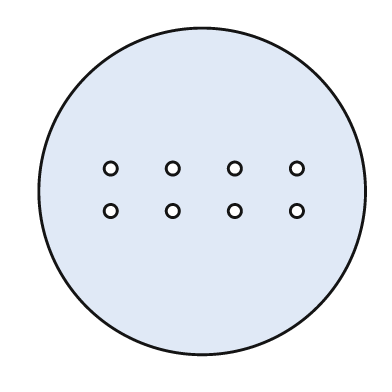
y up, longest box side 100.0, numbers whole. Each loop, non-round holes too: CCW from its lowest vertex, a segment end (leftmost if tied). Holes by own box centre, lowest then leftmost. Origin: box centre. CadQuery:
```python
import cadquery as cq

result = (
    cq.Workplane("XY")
    .moveTo(0.0, 0.0)
    .circle(50.0)
    .moveTo(-28.0, -6.0)
    .circle(2.0)
    .moveTo(-9.0, -6.0)
    .circle(2.0)
    .moveTo(10.0, -6.0)
    .circle(2.0)
    .moveTo(29.0, -6.0)
    .circle(2.0)
    .moveTo(-28.0, 7.0)
    .circle(2.0)
    .moveTo(-9.0, 7.0)
    .circle(2.0)
    .moveTo(10.0, 7.0)
    .circle(2.0)
    .moveTo(29.0, 7.0)
    .circle(2.0)
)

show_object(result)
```